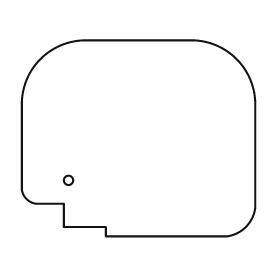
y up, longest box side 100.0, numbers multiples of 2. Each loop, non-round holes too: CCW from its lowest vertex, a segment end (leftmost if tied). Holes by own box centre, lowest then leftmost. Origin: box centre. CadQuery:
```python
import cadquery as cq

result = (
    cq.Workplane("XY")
    .moveTo(-14.0, -42.0)
    .lineTo(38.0, -42.0)
    .threePointArc((46.0, -38.0), (50.0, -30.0))
    .lineTo(50.0, 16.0)
    .threePointArc((42.0, 34.0), (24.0, 42.0))
    .lineTo(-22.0, 42.0)
    .threePointArc((-42.0, 34.0), (-50.0, 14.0))
    .lineTo(-50.0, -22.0)
    .threePointArc((-48.0, -26.0), (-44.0, -28.0))
    .lineTo(-32.0, -28.0)
    .lineTo(-32.0, -38.0)
    .lineTo(-14.0, -38.0)
    .close()
    .moveTo(-30.0, -18.0)
    .circle(2.0)
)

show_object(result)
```